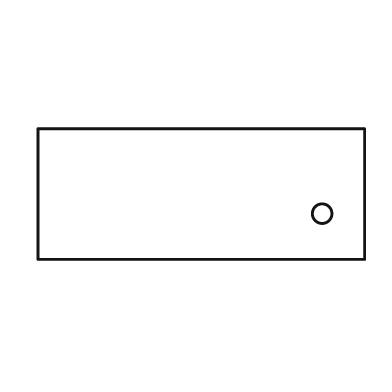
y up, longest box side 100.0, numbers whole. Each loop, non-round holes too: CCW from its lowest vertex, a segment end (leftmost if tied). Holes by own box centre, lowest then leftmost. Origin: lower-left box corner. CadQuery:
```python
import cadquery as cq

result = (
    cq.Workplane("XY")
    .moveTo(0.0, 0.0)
    .lineTo(100.0, 0.0)
    .lineTo(100.0, 40.0)
    .lineTo(0.0, 40.0)
    .close()
    .moveTo(87.0, 14.0)
    .circle(3.0)
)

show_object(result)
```